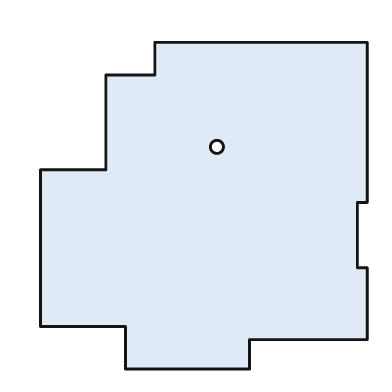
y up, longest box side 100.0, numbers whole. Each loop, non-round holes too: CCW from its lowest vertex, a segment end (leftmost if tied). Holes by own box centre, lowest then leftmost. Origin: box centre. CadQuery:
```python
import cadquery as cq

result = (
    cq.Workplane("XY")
    .moveTo(-24.0, -50.0)
    .lineTo(14.0, -50.0)
    .lineTo(14.0, -41.0)
    .lineTo(50.0, -41.0)
    .lineTo(50.0, -19.0)
    .lineTo(47.0, -19.0)
    .lineTo(47.0, 1.0)
    .lineTo(50.0, 1.0)
    .lineTo(50.0, 50.0)
    .lineTo(-15.0, 50.0)
    .lineTo(-15.0, 40.0)
    .lineTo(-30.0, 40.0)
    .lineTo(-30.0, 11.0)
    .lineTo(-50.0, 11.0)
    .lineTo(-50.0, -37.0)
    .lineTo(-24.0, -37.0)
    .close()
    .moveTo(4.0, 18.0)
    .circle(2.0)
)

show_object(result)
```